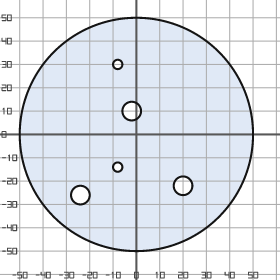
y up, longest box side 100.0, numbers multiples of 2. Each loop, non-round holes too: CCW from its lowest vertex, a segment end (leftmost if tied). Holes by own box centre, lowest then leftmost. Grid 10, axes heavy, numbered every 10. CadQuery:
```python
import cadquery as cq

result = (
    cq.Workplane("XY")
    .moveTo(0.0, 0.0)
    .circle(50.0)
    .moveTo(-24.0, -26.0)
    .circle(4.0)
    .moveTo(20.0, -22.0)
    .circle(4.0)
    .moveTo(-8.0, -14.0)
    .circle(2.0)
    .moveTo(-2.0, 10.0)
    .circle(4.0)
    .moveTo(-8.0, 30.0)
    .circle(2.0)
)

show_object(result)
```